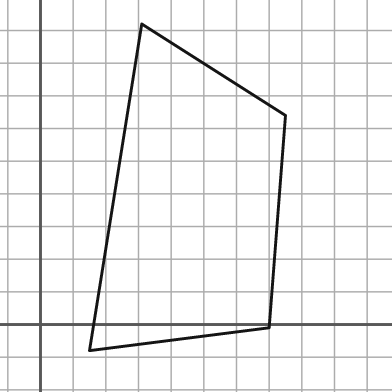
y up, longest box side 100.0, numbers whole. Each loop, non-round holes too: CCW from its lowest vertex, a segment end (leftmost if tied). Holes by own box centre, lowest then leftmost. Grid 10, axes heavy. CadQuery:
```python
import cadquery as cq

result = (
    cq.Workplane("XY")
    .moveTo(15.0, -8.0)
    .lineTo(70.0, -1.0)
    .lineTo(75.0, 64.0)
    .lineTo(31.0, 92.0)
    .close()
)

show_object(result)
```